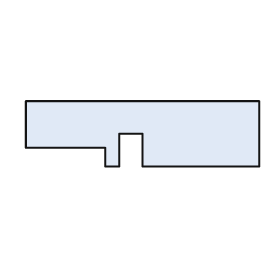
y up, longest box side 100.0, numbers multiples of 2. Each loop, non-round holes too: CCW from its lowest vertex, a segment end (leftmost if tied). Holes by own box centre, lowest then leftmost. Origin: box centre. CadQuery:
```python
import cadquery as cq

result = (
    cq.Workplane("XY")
    .moveTo(-16.0, -14.0)
    .lineTo(-10.0, -14.0)
    .lineTo(-10.0, 0.0)
    .lineTo(0.0, 0.0)
    .lineTo(0.0, -14.0)
    .lineTo(50.0, -14.0)
    .lineTo(50.0, 14.0)
    .lineTo(-50.0, 14.0)
    .lineTo(-50.0, -6.0)
    .lineTo(-16.0, -6.0)
    .close()
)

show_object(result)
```